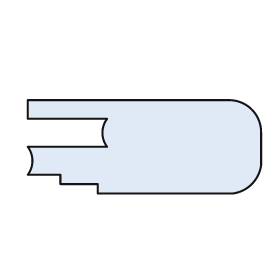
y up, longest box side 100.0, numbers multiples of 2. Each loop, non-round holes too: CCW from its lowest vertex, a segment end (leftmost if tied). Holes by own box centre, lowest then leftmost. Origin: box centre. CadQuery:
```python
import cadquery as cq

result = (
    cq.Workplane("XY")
    .moveTo(-20.0, -20.0)
    .lineTo(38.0, -20.0)
    .threePointArc((46.0, -16.0), (50.0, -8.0))
    .lineTo(50.0, 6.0)
    .threePointArc((46.0, 16.0), (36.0, 20.0))
    .lineTo(-50.0, 20.0)
    .lineTo(-50.0, 12.0)
    .lineTo(-16.0, 12.0)
    .threePointArc((-18.0, 6.0), (-16.0, 0.0))
    .lineTo(-50.0, 0.0)
    .threePointArc((-48.0, -6.0), (-50.0, -12.0))
    .lineTo(-36.0, -12.0)
    .lineTo(-36.0, -16.0)
    .lineTo(-20.0, -16.0)
    .close()
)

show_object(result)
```